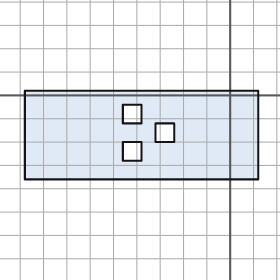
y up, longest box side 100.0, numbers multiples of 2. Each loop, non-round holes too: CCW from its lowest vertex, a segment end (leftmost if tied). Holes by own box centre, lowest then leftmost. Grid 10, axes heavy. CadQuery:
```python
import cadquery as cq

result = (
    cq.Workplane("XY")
    .moveTo(-88.0, -36.0)
    .lineTo(12.0, -36.0)
    .lineTo(12.0, 2.0)
    .lineTo(-88.0, 2.0)
    .close()
    .moveTo(-46.0, -28.0)
    .lineTo(-38.0, -28.0)
    .lineTo(-38.0, -20.0)
    .lineTo(-46.0, -20.0)
    .close()
    .moveTo(-32.0, -20.0)
    .lineTo(-24.0, -20.0)
    .lineTo(-24.0, -12.0)
    .lineTo(-32.0, -12.0)
    .close()
    .moveTo(-46.0, -12.0)
    .lineTo(-38.0, -12.0)
    .lineTo(-38.0, -4.0)
    .lineTo(-46.0, -4.0)
    .close()
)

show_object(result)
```